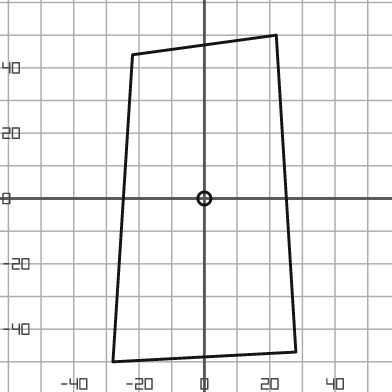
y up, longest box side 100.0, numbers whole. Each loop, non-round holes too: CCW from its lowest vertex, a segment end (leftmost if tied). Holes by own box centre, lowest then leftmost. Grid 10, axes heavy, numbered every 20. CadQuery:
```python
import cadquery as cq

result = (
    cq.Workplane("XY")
    .moveTo(-28.0, -50.0)
    .lineTo(28.0, -47.0)
    .lineTo(22.0, 50.0)
    .lineTo(-22.0, 44.0)
    .close()
    .moveTo(0.0, 0.0)
    .circle(2.0)
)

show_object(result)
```